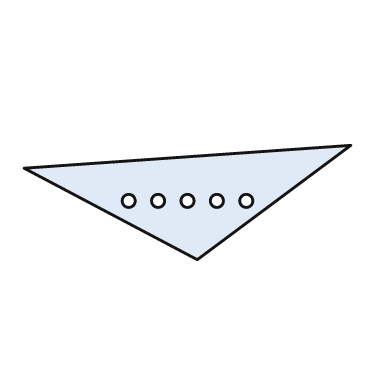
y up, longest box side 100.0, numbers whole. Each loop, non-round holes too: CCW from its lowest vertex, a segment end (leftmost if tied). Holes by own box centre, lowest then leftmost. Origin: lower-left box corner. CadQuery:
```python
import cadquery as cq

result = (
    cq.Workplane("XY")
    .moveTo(53.0, 0.0)
    .lineTo(100.0, 35.0)
    .lineTo(0.0, 28.0)
    .close()
    .moveTo(32.0, 18.0)
    .circle(2.0)
    .moveTo(41.0, 18.0)
    .circle(2.0)
    .moveTo(50.0, 18.0)
    .circle(2.0)
    .moveTo(59.0, 18.0)
    .circle(2.0)
    .moveTo(68.0, 18.0)
    .circle(2.0)
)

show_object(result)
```